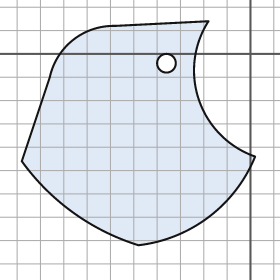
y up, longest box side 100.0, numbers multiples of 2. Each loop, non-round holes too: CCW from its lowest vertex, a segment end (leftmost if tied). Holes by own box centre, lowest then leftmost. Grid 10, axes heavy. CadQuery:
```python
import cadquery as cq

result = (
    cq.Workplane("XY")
    .moveTo(-48.0, -82.0)
    .threePointArc((-18.0, -70.0), (2.0, -44.0))
    .threePointArc((-22.0, -20.0), (-18.0, 14.0))
    .lineTo(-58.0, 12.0)
    .threePointArc((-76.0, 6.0), (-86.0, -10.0))
    .lineTo(-98.0, -46.0)
    .threePointArc((-76.0, -68.0), (-48.0, -82.0))
    .close()
    .moveTo(-36.0, -4.0)
    .circle(4.0)
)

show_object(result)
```